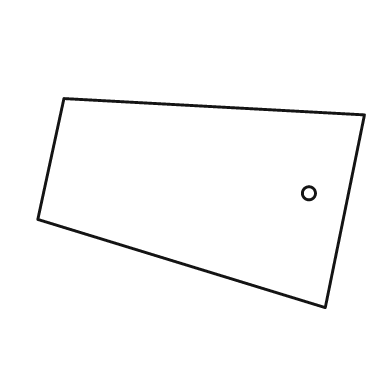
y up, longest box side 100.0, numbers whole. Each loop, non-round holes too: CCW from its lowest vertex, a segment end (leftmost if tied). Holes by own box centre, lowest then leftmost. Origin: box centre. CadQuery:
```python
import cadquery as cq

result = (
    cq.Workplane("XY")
    .moveTo(38.0, -32.0)
    .lineTo(50.0, 27.0)
    .lineTo(-42.0, 32.0)
    .lineTo(-50.0, -5.0)
    .close()
    .moveTo(33.0, 3.0)
    .circle(2.0)
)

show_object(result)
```